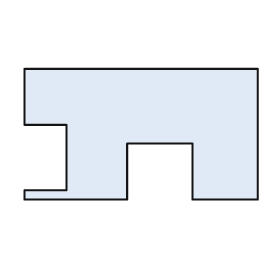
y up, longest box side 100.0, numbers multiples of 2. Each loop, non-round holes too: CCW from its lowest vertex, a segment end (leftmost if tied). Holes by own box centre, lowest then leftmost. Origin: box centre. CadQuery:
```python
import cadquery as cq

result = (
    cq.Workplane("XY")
    .moveTo(-50.0, -28.0)
    .lineTo(-6.0, -28.0)
    .lineTo(-6.0, -4.0)
    .lineTo(22.0, -4.0)
    .lineTo(22.0, -28.0)
    .lineTo(50.0, -28.0)
    .lineTo(50.0, 28.0)
    .lineTo(-50.0, 28.0)
    .lineTo(-50.0, 4.0)
    .lineTo(-32.0, 4.0)
    .lineTo(-32.0, -24.0)
    .lineTo(-50.0, -24.0)
    .close()
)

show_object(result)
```